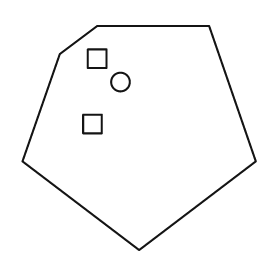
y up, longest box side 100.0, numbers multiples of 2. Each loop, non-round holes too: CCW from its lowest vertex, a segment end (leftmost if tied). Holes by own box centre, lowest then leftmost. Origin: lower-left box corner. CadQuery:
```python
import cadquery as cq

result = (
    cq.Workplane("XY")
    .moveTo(50.0, 0.0)
    .lineTo(100.0, 38.0)
    .lineTo(80.0, 96.0)
    .lineTo(32.0, 96.0)
    .lineTo(16.0, 84.0)
    .lineTo(0.0, 38.0)
    .close()
    .moveTo(26.0, 50.0)
    .lineTo(34.0, 50.0)
    .lineTo(34.0, 58.0)
    .lineTo(26.0, 58.0)
    .close()
    .moveTo(42.0, 72.0)
    .circle(4.0)
    .moveTo(28.0, 78.0)
    .lineTo(36.0, 78.0)
    .lineTo(36.0, 86.0)
    .lineTo(28.0, 86.0)
    .close()
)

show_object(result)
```